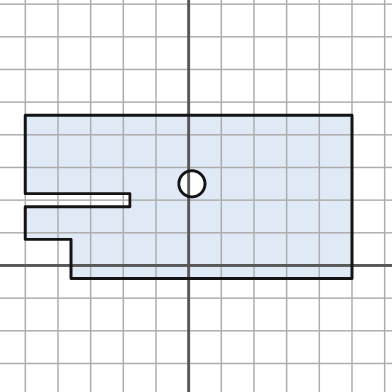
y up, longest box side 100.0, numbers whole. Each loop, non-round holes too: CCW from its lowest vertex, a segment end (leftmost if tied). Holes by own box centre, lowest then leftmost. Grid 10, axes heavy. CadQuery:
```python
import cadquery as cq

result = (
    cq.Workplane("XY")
    .moveTo(-36.0, -4.0)
    .lineTo(50.0, -4.0)
    .lineTo(50.0, 46.0)
    .lineTo(-50.0, 46.0)
    .lineTo(-50.0, 22.0)
    .lineTo(-18.0, 22.0)
    .lineTo(-18.0, 18.0)
    .lineTo(-50.0, 18.0)
    .lineTo(-50.0, 8.0)
    .lineTo(-36.0, 8.0)
    .close()
    .moveTo(1.0, 25.0)
    .circle(4.0)
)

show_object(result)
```